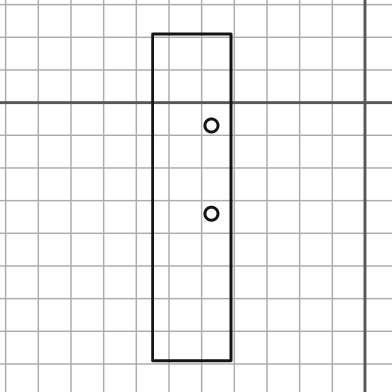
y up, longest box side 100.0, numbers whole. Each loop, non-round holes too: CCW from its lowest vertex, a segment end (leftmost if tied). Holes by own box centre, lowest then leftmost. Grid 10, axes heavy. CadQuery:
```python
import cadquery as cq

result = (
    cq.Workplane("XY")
    .moveTo(-65.0, -79.0)
    .lineTo(-41.0, -79.0)
    .lineTo(-41.0, 21.0)
    .lineTo(-65.0, 21.0)
    .close()
    .moveTo(-47.0, -34.0)
    .circle(2.0)
    .moveTo(-47.0, -7.0)
    .circle(2.0)
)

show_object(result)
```